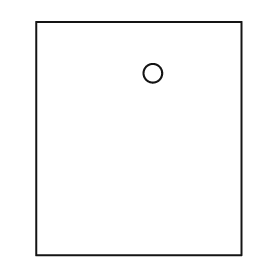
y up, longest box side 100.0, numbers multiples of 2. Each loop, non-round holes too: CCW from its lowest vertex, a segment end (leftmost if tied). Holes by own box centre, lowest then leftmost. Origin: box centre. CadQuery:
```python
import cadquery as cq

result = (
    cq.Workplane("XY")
    .moveTo(-44.0, -50.0)
    .lineTo(44.0, -50.0)
    .lineTo(44.0, 50.0)
    .lineTo(-44.0, 50.0)
    .close()
    .moveTo(6.0, 28.0)
    .circle(4.0)
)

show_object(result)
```